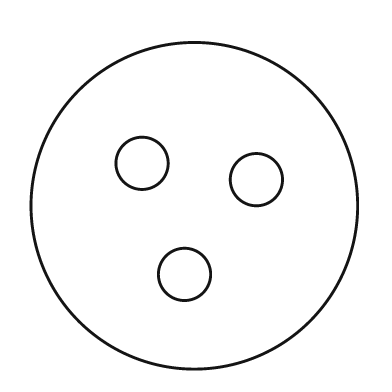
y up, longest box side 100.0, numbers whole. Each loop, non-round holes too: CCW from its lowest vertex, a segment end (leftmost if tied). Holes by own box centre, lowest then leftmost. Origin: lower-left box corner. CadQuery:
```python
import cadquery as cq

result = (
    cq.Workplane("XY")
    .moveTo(50.0, 50.0)
    .circle(50.0)
    .moveTo(47.0, 29.0)
    .circle(8.0)
    .moveTo(69.0, 58.0)
    .circle(8.0)
    .moveTo(34.0, 63.0)
    .circle(8.0)
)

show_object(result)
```